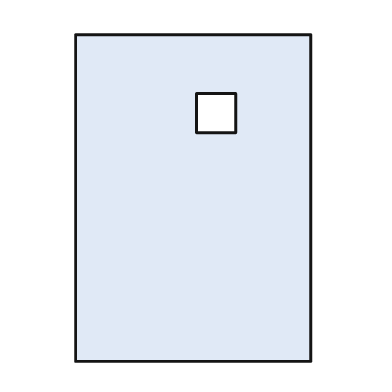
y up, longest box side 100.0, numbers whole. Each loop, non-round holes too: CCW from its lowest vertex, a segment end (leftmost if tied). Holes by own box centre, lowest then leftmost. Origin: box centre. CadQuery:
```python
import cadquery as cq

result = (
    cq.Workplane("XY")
    .moveTo(-36.0, -50.0)
    .lineTo(36.0, -50.0)
    .lineTo(36.0, 50.0)
    .lineTo(-36.0, 50.0)
    .close()
    .moveTo(1.0, 20.0)
    .lineTo(13.0, 20.0)
    .lineTo(13.0, 32.0)
    .lineTo(1.0, 32.0)
    .close()
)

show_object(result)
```